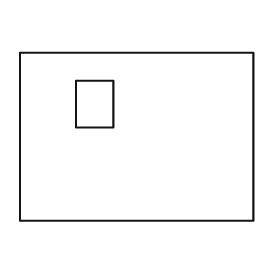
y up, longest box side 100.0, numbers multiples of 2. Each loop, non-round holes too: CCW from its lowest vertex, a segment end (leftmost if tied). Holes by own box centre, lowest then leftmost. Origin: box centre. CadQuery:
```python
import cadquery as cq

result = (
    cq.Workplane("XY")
    .moveTo(-50.0, -36.0)
    .lineTo(50.0, -36.0)
    .lineTo(50.0, 36.0)
    .lineTo(-50.0, 36.0)
    .close()
    .moveTo(-26.0, 4.0)
    .lineTo(-10.0, 4.0)
    .lineTo(-10.0, 24.0)
    .lineTo(-26.0, 24.0)
    .close()
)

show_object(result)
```